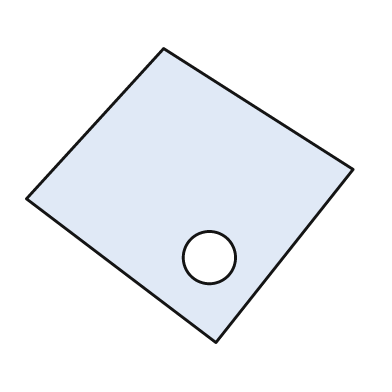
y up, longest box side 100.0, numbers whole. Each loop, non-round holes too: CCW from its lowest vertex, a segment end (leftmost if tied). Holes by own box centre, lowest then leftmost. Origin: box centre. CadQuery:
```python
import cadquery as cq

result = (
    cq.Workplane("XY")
    .moveTo(8.0, -45.0)
    .lineTo(50.0, 8.0)
    .lineTo(-8.0, 45.0)
    .lineTo(-50.0, -1.0)
    .close()
    .moveTo(6.0, -19.0)
    .circle(8.0)
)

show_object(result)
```